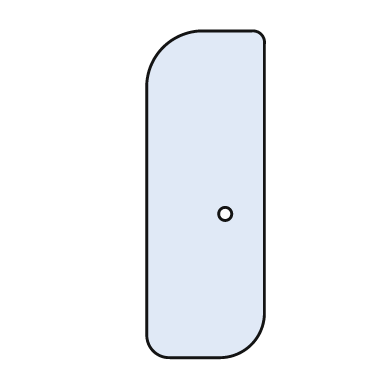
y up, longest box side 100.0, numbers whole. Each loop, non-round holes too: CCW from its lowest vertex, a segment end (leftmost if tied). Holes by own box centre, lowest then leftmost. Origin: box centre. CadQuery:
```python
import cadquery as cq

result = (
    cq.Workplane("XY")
    .moveTo(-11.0, -50.0)
    .lineTo(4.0, -50.0)
    .threePointArc((14.0, -46.0), (18.0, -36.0))
    .lineTo(18.0, 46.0)
    .threePointArc((17.0, 49.0), (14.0, 50.0))
    .lineTo(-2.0, 50.0)
    .threePointArc((-13.0, 45.0), (-18.0, 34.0))
    .lineTo(-18.0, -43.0)
    .threePointArc((-16.0, -48.0), (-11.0, -50.0))
    .close()
    .moveTo(6.0, -6.0)
    .circle(2.0)
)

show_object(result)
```